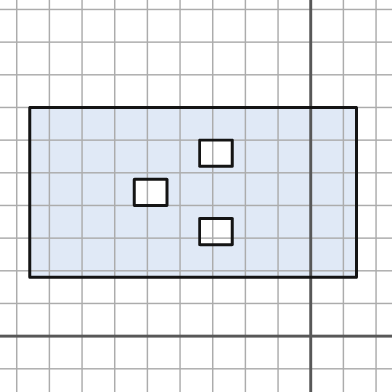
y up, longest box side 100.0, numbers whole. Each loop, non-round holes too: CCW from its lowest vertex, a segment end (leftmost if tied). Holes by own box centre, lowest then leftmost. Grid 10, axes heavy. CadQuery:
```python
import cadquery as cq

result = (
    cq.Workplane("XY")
    .moveTo(-86.0, 18.0)
    .lineTo(14.0, 18.0)
    .lineTo(14.0, 70.0)
    .lineTo(-86.0, 70.0)
    .close()
    .moveTo(-34.0, 28.0)
    .lineTo(-24.0, 28.0)
    .lineTo(-24.0, 36.0)
    .lineTo(-34.0, 36.0)
    .close()
    .moveTo(-54.0, 40.0)
    .lineTo(-44.0, 40.0)
    .lineTo(-44.0, 48.0)
    .lineTo(-54.0, 48.0)
    .close()
    .moveTo(-34.0, 52.0)
    .lineTo(-24.0, 52.0)
    .lineTo(-24.0, 60.0)
    .lineTo(-34.0, 60.0)
    .close()
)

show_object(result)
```